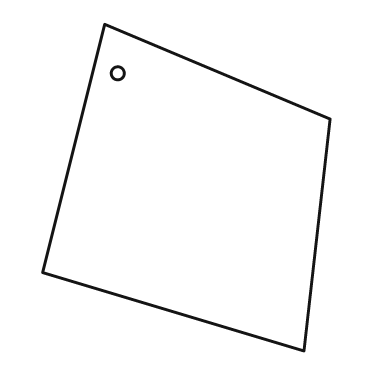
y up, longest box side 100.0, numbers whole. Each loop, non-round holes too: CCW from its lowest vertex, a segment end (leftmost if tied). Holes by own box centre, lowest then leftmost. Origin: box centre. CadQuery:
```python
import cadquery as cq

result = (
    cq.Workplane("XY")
    .moveTo(36.0, -50.0)
    .lineTo(44.0, 21.0)
    .lineTo(-25.0, 50.0)
    .lineTo(-44.0, -26.0)
    .close()
    .moveTo(-21.0, 35.0)
    .circle(2.0)
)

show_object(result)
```